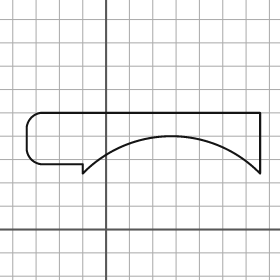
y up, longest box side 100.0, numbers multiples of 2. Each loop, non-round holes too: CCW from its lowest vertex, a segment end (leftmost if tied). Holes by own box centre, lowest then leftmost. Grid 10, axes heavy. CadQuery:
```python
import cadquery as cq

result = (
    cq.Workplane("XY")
    .moveTo(-10.0, 24.0)
    .threePointArc((28.0, 40.0), (66.0, 24.0))
    .lineTo(66.0, 50.0)
    .lineTo(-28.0, 50.0)
    .threePointArc((-32.0, 48.0), (-34.0, 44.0))
    .lineTo(-34.0, 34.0)
    .threePointArc((-32.0, 30.0), (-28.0, 28.0))
    .lineTo(-10.0, 28.0)
    .close()
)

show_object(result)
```